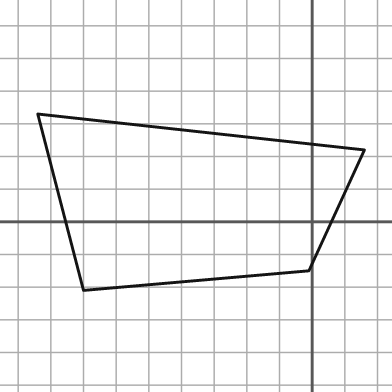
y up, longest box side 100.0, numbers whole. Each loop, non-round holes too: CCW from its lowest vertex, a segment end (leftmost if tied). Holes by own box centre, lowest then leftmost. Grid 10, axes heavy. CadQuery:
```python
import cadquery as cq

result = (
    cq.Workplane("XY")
    .moveTo(-70.0, -21.0)
    .lineTo(-1.0, -15.0)
    .lineTo(16.0, 22.0)
    .lineTo(-84.0, 33.0)
    .close()
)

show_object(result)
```